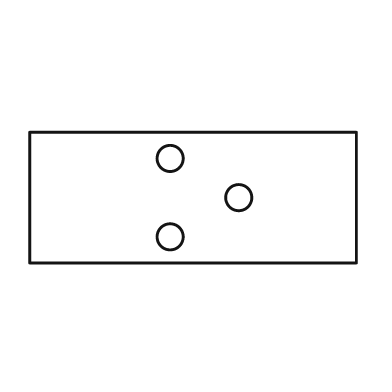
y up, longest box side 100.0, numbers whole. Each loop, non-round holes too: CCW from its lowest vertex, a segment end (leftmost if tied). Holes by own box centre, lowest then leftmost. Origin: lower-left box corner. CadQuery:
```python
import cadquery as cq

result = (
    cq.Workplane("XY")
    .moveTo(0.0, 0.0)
    .lineTo(100.0, 0.0)
    .lineTo(100.0, 40.0)
    .lineTo(0.0, 40.0)
    .close()
    .moveTo(43.0, 8.0)
    .circle(4.0)
    .moveTo(64.0, 20.0)
    .circle(4.0)
    .moveTo(43.0, 32.0)
    .circle(4.0)
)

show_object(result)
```